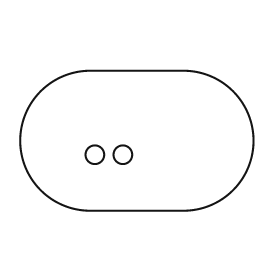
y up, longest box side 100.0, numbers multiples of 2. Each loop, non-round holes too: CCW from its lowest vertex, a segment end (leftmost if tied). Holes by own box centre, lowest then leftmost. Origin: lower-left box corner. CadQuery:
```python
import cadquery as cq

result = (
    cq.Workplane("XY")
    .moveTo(30.0, 0.0)
    .lineTo(70.0, 0.0)
    .threePointArc((100.0, 30.0), (70.0, 60.0))
    .lineTo(30.0, 60.0)
    .threePointArc((0.0, 30.0), (30.0, 0.0))
    .close()
    .moveTo(32.0, 24.0)
    .circle(4.0)
    .moveTo(44.0, 24.0)
    .circle(4.0)
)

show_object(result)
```